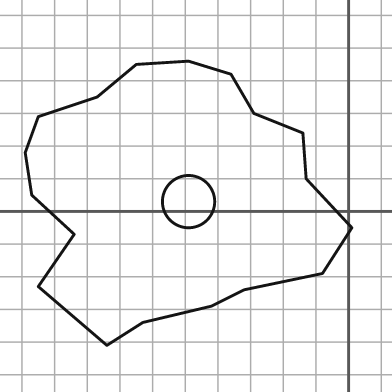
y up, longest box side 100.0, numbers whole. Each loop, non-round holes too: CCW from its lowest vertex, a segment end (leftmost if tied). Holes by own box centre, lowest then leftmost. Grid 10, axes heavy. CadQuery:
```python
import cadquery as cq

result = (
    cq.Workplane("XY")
    .moveTo(-74.0, -41.0)
    .lineTo(-63.0, -34.0)
    .lineTo(-42.0, -29.0)
    .lineTo(-32.0, -24.0)
    .lineTo(-8.0, -19.0)
    .lineTo(1.0, -5.0)
    .lineTo(-13.0, 10.0)
    .lineTo(-14.0, 24.0)
    .lineTo(-29.0, 30.0)
    .lineTo(-36.0, 42.0)
    .lineTo(-49.0, 46.0)
    .lineTo(-65.0, 45.0)
    .lineTo(-77.0, 35.0)
    .lineTo(-95.0, 29.0)
    .lineTo(-99.0, 18.0)
    .lineTo(-97.0, 5.0)
    .lineTo(-84.0, -7.0)
    .lineTo(-95.0, -23.0)
    .close()
    .moveTo(-49.0, 3.0)
    .circle(8.0)
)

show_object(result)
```